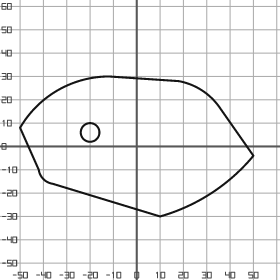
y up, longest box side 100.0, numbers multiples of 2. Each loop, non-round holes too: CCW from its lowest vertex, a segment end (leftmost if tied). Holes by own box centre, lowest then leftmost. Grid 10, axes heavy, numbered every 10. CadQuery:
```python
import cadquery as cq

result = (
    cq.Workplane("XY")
    .moveTo(10.0, -30.0)
    .threePointArc((32.0, -20.0), (50.0, -4.0))
    .lineTo(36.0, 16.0)
    .threePointArc((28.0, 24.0), (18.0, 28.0))
    .lineTo(-12.0, 30.0)
    .threePointArc((-34.0, 24.0), (-50.0, 8.0))
    .lineTo(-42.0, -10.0)
    .threePointArc((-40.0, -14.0), (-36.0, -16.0))
    .close()
    .moveTo(-20.0, 6.0)
    .circle(4.0)
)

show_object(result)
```